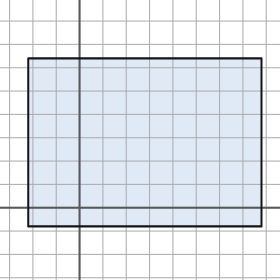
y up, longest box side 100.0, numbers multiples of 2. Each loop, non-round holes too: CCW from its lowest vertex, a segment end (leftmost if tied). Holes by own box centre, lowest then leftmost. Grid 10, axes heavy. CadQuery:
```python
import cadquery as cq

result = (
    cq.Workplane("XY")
    .moveTo(-22.0, -8.0)
    .lineTo(78.0, -8.0)
    .lineTo(78.0, 64.0)
    .lineTo(-22.0, 64.0)
    .close()
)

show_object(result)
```